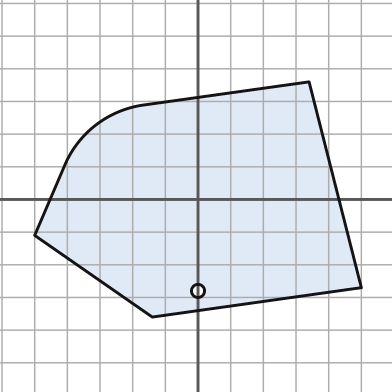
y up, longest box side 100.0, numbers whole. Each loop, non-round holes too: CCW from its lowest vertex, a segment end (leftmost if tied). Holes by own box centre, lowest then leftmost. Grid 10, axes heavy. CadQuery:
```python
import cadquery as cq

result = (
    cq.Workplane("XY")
    .moveTo(-14.0, -36.0)
    .lineTo(50.0, -27.0)
    .lineTo(34.0, 36.0)
    .lineTo(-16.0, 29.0)
    .threePointArc((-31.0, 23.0), (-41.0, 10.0))
    .lineTo(-50.0, -11.0)
    .close()
    .moveTo(0.0, -28.0)
    .circle(2.0)
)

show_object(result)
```